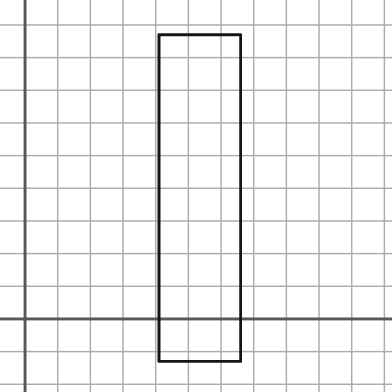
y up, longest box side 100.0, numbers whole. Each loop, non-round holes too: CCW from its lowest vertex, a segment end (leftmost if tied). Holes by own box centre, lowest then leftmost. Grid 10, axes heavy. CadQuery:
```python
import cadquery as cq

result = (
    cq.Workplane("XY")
    .moveTo(41.0, -13.0)
    .lineTo(66.0, -13.0)
    .lineTo(66.0, 87.0)
    .lineTo(41.0, 87.0)
    .close()
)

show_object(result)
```